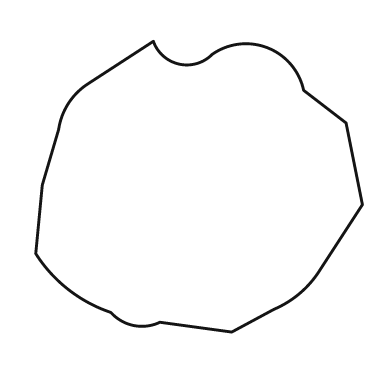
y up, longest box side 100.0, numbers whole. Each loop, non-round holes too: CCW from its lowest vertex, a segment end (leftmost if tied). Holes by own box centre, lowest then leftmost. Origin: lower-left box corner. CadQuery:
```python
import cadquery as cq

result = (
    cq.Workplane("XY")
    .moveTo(60.0, 0.0)
    .lineTo(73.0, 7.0)
    .threePointArc((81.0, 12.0), (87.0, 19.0))
    .lineTo(100.0, 39.0)
    .lineTo(95.0, 64.0)
    .lineTo(82.0, 74.0)
    .threePointArc((71.0, 87.0), (54.0, 85.0))
    .threePointArc((44.0, 82.0), (36.0, 89.0))
    .lineTo(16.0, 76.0)
    .threePointArc((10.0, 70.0), (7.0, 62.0))
    .lineTo(2.0, 45.0)
    .lineTo(0.0, 24.0)
    .threePointArc((10.0, 13.0), (23.0, 6.0))
    .threePointArc((30.0, 2.0), (38.0, 3.0))
    .close()
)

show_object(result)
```